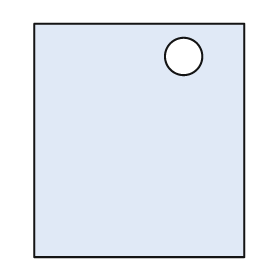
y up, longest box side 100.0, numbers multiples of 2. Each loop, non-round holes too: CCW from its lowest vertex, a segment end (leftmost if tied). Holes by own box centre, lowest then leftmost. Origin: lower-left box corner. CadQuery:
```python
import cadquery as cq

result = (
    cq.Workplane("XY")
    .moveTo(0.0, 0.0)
    .lineTo(90.0, 0.0)
    .lineTo(90.0, 100.0)
    .lineTo(0.0, 100.0)
    .close()
    .moveTo(64.0, 86.0)
    .circle(8.0)
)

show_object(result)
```